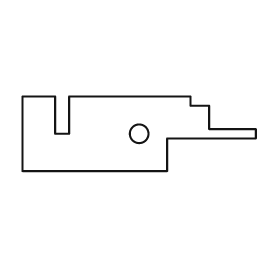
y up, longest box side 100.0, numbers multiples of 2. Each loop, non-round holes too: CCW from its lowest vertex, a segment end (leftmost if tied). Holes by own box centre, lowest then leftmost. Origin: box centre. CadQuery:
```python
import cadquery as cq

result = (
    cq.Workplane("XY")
    .moveTo(-50.0, -16.0)
    .lineTo(12.0, -16.0)
    .lineTo(12.0, -2.0)
    .lineTo(50.0, -2.0)
    .lineTo(50.0, 2.0)
    .lineTo(30.0, 2.0)
    .lineTo(30.0, 12.0)
    .lineTo(22.0, 12.0)
    .lineTo(22.0, 16.0)
    .lineTo(-30.0, 16.0)
    .lineTo(-30.0, 0.0)
    .lineTo(-36.0, 0.0)
    .lineTo(-36.0, 16.0)
    .lineTo(-50.0, 16.0)
    .close()
    .moveTo(0.0, 0.0)
    .circle(4.0)
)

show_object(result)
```